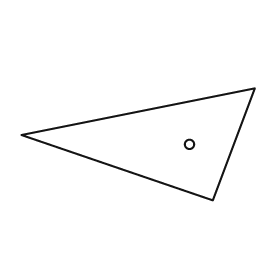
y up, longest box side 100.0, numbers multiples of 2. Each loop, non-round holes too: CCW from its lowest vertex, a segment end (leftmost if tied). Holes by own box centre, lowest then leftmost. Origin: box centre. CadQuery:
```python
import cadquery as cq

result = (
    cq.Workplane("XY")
    .moveTo(32.0, -24.0)
    .lineTo(50.0, 24.0)
    .lineTo(-50.0, 4.0)
    .close()
    .moveTo(22.0, 0.0)
    .circle(2.0)
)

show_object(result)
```